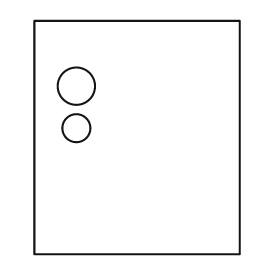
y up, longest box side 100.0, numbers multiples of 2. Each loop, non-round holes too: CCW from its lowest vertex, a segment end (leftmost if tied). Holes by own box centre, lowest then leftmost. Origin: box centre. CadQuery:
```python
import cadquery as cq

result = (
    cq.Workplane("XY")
    .moveTo(-44.0, -50.0)
    .lineTo(44.0, -50.0)
    .lineTo(44.0, 50.0)
    .lineTo(-44.0, 50.0)
    .close()
    .moveTo(-26.0, 4.0)
    .circle(6.0)
    .moveTo(-26.0, 22.0)
    .circle(8.0)
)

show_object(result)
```